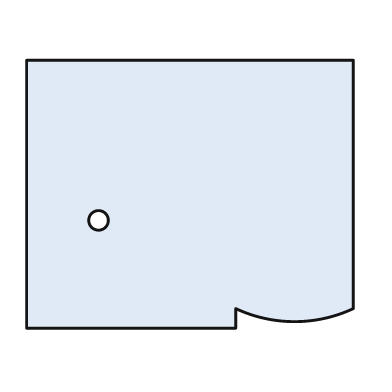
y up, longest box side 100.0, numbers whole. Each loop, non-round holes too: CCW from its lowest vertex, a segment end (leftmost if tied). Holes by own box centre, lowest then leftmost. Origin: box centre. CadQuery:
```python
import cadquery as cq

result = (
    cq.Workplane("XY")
    .moveTo(-50.0, -41.0)
    .lineTo(14.0, -41.0)
    .lineTo(14.0, -35.0)
    .threePointArc((32.0, -39.0), (50.0, -35.0))
    .lineTo(50.0, 41.0)
    .lineTo(-50.0, 41.0)
    .close()
    .moveTo(-28.0, -8.0)
    .circle(3.0)
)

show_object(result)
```